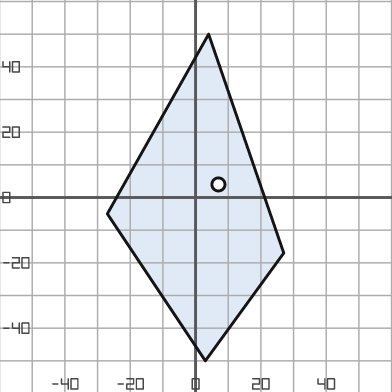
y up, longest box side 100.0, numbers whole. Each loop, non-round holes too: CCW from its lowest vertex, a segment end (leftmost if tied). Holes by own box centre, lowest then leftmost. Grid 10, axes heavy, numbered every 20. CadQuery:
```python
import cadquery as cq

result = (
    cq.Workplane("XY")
    .moveTo(3.0, -50.0)
    .lineTo(27.0, -17.0)
    .lineTo(4.0, 50.0)
    .lineTo(-27.0, -5.0)
    .close()
    .moveTo(7.0, 4.0)
    .circle(2.0)
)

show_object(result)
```